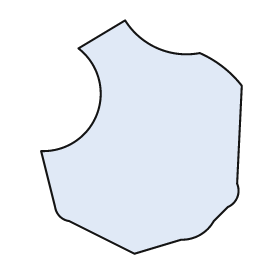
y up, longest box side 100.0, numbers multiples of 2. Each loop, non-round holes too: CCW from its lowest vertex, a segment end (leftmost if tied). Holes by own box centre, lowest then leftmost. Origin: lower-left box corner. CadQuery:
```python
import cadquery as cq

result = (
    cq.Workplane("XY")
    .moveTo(40.0, 0.0)
    .lineTo(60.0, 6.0)
    .threePointArc((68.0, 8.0), (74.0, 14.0))
    .lineTo(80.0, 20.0)
    .threePointArc((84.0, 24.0), (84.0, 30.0))
    .lineTo(86.0, 72.0)
    .threePointArc((78.0, 80.0), (68.0, 86.0))
    .threePointArc((50.0, 88.0), (36.0, 100.0))
    .lineTo(16.0, 88.0)
    .threePointArc((24.0, 60.0), (0.0, 44.0))
    .lineTo(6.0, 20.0)
    .threePointArc((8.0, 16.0), (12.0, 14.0))
    .close()
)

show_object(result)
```